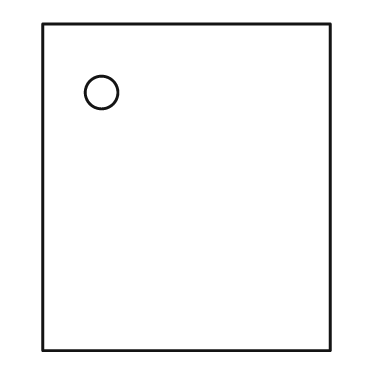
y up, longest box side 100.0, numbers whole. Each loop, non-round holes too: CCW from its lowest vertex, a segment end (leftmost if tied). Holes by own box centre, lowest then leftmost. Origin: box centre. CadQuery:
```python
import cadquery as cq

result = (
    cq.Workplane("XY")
    .moveTo(-44.0, -50.0)
    .lineTo(44.0, -50.0)
    .lineTo(44.0, 50.0)
    .lineTo(-44.0, 50.0)
    .close()
    .moveTo(-26.0, 29.0)
    .circle(5.0)
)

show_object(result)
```